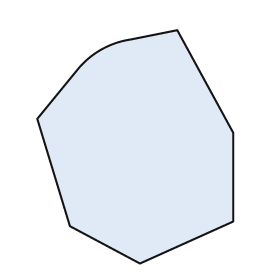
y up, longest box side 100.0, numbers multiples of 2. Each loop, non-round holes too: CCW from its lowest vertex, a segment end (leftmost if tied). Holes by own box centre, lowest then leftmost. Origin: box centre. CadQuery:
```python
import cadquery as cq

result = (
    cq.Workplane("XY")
    .moveTo(2.0, -50.0)
    .lineTo(42.0, -32.0)
    .lineTo(42.0, 6.0)
    .lineTo(18.0, 50.0)
    .lineTo(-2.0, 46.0)
    .threePointArc((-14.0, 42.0), (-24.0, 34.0))
    .lineTo(-42.0, 12.0)
    .lineTo(-28.0, -34.0)
    .close()
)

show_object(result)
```